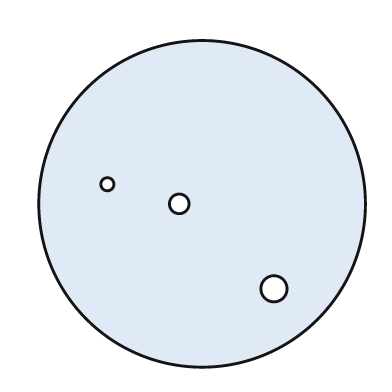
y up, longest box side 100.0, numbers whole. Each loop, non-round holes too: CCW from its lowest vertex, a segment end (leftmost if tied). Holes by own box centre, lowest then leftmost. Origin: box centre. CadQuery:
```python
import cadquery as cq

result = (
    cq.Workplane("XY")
    .moveTo(0.0, 0.0)
    .circle(50.0)
    .moveTo(22.0, -26.0)
    .circle(4.0)
    .moveTo(-7.0, 0.0)
    .circle(3.0)
    .moveTo(-29.0, 6.0)
    .circle(2.0)
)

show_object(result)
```